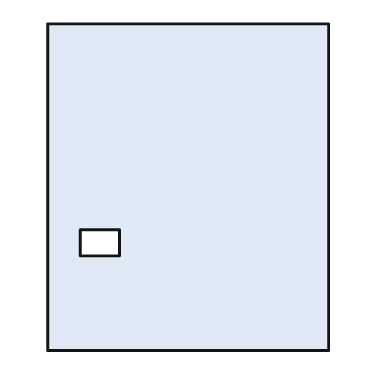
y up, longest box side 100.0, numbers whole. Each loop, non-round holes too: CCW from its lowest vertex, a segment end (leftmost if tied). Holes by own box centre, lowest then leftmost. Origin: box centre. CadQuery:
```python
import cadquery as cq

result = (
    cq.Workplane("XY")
    .moveTo(-43.0, -50.0)
    .lineTo(43.0, -50.0)
    .lineTo(43.0, 50.0)
    .lineTo(-43.0, 50.0)
    .close()
    .moveTo(-33.0, -21.0)
    .lineTo(-21.0, -21.0)
    .lineTo(-21.0, -13.0)
    .lineTo(-33.0, -13.0)
    .close()
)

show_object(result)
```